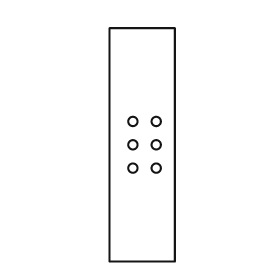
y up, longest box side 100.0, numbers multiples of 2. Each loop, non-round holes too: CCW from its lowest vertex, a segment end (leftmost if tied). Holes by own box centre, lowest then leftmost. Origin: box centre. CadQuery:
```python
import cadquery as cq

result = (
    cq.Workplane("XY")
    .moveTo(-14.0, -50.0)
    .lineTo(14.0, -50.0)
    .lineTo(14.0, 50.0)
    .lineTo(-14.0, 50.0)
    .close()
    .moveTo(-4.0, -10.0)
    .circle(2.0)
    .moveTo(6.0, -10.0)
    .circle(2.0)
    .moveTo(-4.0, 0.0)
    .circle(2.0)
    .moveTo(6.0, 0.0)
    .circle(2.0)
    .moveTo(-4.0, 10.0)
    .circle(2.0)
    .moveTo(6.0, 10.0)
    .circle(2.0)
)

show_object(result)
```